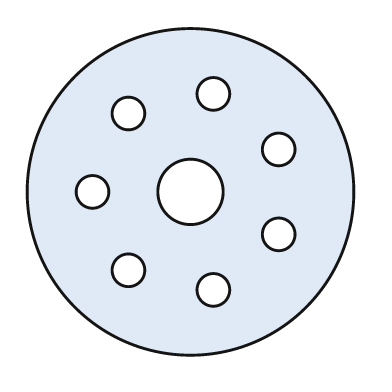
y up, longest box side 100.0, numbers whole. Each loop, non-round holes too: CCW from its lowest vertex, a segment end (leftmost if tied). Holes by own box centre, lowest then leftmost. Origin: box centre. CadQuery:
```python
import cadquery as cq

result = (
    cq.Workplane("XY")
    .moveTo(0.0, 0.0)
    .circle(50.0)
    .moveTo(7.0, -30.0)
    .circle(5.0)
    .moveTo(-19.0, -24.0)
    .circle(5.0)
    .moveTo(27.0, -13.0)
    .circle(5.0)
    .moveTo(-30.0, 0.0)
    .circle(5.0)
    .moveTo(0.0, 0.0)
    .circle(10.0)
    .moveTo(27.0, 13.0)
    .circle(5.0)
    .moveTo(-19.0, 24.0)
    .circle(5.0)
    .moveTo(7.0, 30.0)
    .circle(5.0)
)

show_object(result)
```